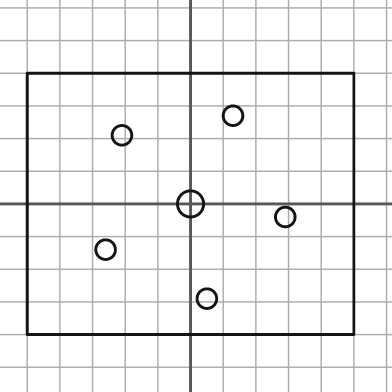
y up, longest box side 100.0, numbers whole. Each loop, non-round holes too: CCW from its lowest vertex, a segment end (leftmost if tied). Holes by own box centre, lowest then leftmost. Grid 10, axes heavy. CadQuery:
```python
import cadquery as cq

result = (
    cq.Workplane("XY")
    .moveTo(-50.0, -40.0)
    .lineTo(50.0, -40.0)
    .lineTo(50.0, 40.0)
    .lineTo(-50.0, 40.0)
    .close()
    .moveTo(5.0, -29.0)
    .circle(3.0)
    .moveTo(-26.0, -14.0)
    .circle(3.0)
    .moveTo(29.0, -4.0)
    .circle(3.0)
    .moveTo(0.0, 0.0)
    .circle(4.0)
    .moveTo(-21.0, 21.0)
    .circle(3.0)
    .moveTo(13.0, 27.0)
    .circle(3.0)
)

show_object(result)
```